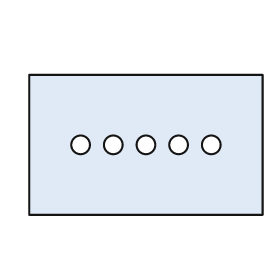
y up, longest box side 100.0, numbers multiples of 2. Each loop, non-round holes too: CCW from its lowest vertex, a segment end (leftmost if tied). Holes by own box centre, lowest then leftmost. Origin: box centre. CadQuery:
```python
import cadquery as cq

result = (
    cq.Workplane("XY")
    .moveTo(-50.0, -30.0)
    .lineTo(50.0, -30.0)
    .lineTo(50.0, 30.0)
    .lineTo(-50.0, 30.0)
    .close()
    .moveTo(-28.0, 0.0)
    .circle(4.0)
    .moveTo(-14.0, 0.0)
    .circle(4.0)
    .moveTo(0.0, 0.0)
    .circle(4.0)
    .moveTo(14.0, 0.0)
    .circle(4.0)
    .moveTo(28.0, 0.0)
    .circle(4.0)
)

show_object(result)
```